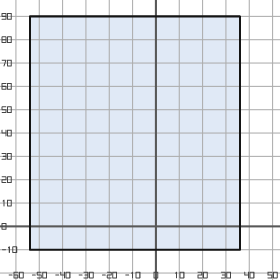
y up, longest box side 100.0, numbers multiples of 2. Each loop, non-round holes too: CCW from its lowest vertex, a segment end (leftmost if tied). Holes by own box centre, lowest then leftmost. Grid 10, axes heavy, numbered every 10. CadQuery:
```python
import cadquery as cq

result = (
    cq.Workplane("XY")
    .moveTo(-54.0, -10.0)
    .lineTo(36.0, -10.0)
    .lineTo(36.0, 90.0)
    .lineTo(-54.0, 90.0)
    .close()
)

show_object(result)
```